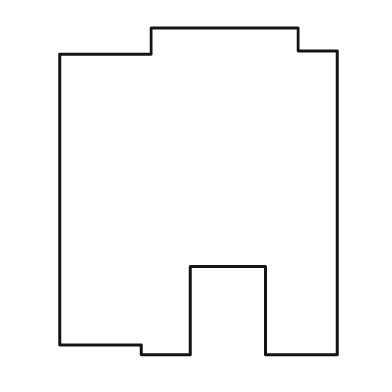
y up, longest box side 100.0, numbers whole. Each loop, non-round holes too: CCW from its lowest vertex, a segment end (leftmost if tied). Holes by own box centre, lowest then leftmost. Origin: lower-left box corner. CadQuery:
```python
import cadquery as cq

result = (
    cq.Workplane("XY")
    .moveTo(25.0, 0.0)
    .lineTo(40.0, 0.0)
    .lineTo(40.0, 27.0)
    .lineTo(63.0, 27.0)
    .lineTo(63.0, 0.0)
    .lineTo(85.0, 0.0)
    .lineTo(85.0, 93.0)
    .lineTo(73.0, 93.0)
    .lineTo(73.0, 100.0)
    .lineTo(28.0, 100.0)
    .lineTo(28.0, 92.0)
    .lineTo(0.0, 92.0)
    .lineTo(0.0, 3.0)
    .lineTo(25.0, 3.0)
    .close()
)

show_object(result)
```